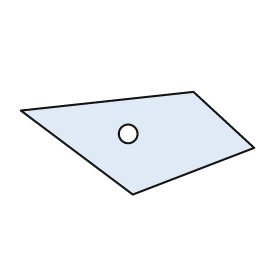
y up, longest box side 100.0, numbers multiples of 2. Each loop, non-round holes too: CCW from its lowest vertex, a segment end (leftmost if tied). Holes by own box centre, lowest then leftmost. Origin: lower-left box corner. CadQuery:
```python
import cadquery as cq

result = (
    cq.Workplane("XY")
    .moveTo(48.0, 0.0)
    .lineTo(100.0, 20.0)
    .lineTo(74.0, 44.0)
    .lineTo(0.0, 36.0)
    .close()
    .moveTo(46.0, 26.0)
    .circle(4.0)
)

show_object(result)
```